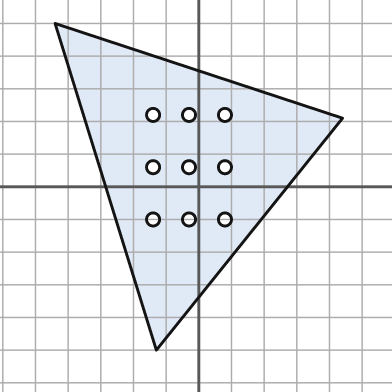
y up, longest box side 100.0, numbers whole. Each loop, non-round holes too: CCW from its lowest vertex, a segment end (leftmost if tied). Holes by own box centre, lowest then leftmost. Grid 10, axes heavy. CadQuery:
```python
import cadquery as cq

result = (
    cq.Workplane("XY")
    .moveTo(-13.0, -50.0)
    .lineTo(44.0, 21.0)
    .lineTo(-44.0, 50.0)
    .close()
    .moveTo(-14.0, -10.0)
    .circle(2.0)
    .moveTo(-3.0, -10.0)
    .circle(2.0)
    .moveTo(8.0, -10.0)
    .circle(2.0)
    .moveTo(-14.0, 6.0)
    .circle(2.0)
    .moveTo(-3.0, 6.0)
    .circle(2.0)
    .moveTo(8.0, 6.0)
    .circle(2.0)
    .moveTo(-14.0, 22.0)
    .circle(2.0)
    .moveTo(-3.0, 22.0)
    .circle(2.0)
    .moveTo(8.0, 22.0)
    .circle(2.0)
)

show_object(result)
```